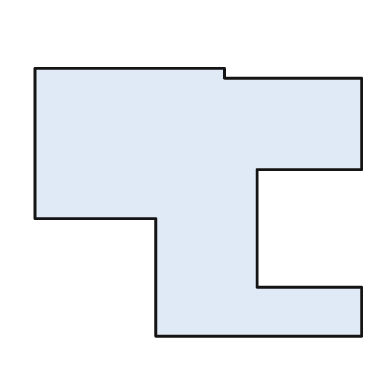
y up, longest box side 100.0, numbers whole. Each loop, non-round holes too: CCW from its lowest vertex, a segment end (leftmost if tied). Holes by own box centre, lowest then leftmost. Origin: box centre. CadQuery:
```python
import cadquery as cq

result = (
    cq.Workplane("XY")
    .moveTo(-13.0, -41.0)
    .lineTo(50.0, -41.0)
    .lineTo(50.0, -26.0)
    .lineTo(18.0, -26.0)
    .lineTo(18.0, 10.0)
    .lineTo(50.0, 10.0)
    .lineTo(50.0, 38.0)
    .lineTo(8.0, 38.0)
    .lineTo(8.0, 41.0)
    .lineTo(-50.0, 41.0)
    .lineTo(-50.0, -5.0)
    .lineTo(-13.0, -5.0)
    .close()
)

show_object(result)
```